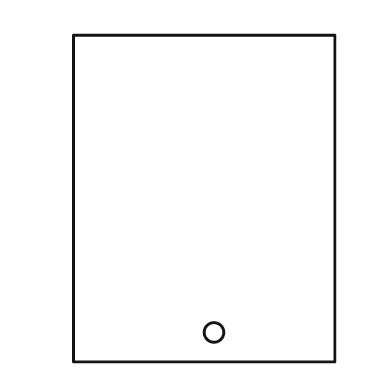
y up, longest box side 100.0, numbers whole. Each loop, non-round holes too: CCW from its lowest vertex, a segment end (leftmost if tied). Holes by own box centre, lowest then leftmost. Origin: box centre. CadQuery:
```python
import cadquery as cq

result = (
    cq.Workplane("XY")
    .moveTo(-40.0, -50.0)
    .lineTo(40.0, -50.0)
    .lineTo(40.0, 50.0)
    .lineTo(-40.0, 50.0)
    .close()
    .moveTo(3.0, -41.0)
    .circle(3.0)
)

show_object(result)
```